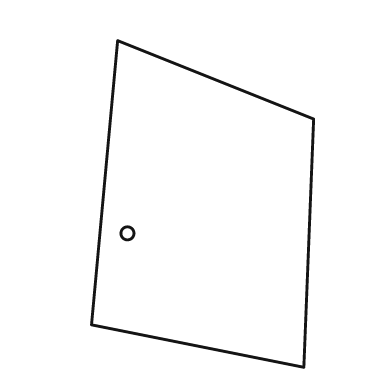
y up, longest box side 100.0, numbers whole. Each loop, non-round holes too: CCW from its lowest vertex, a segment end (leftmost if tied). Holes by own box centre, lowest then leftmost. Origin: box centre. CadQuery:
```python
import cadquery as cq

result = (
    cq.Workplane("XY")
    .moveTo(31.0, -50.0)
    .lineTo(34.0, 26.0)
    .lineTo(-26.0, 50.0)
    .lineTo(-34.0, -37.0)
    .close()
    .moveTo(-23.0, -9.0)
    .circle(2.0)
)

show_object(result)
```